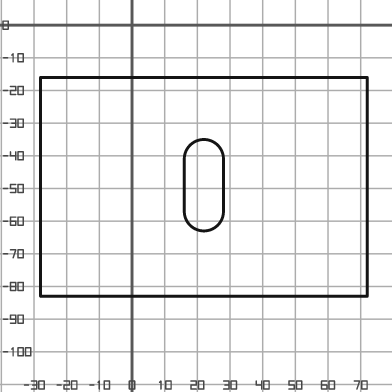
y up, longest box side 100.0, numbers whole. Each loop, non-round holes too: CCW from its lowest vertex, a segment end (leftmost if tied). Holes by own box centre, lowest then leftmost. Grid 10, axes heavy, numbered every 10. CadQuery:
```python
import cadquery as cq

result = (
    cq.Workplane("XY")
    .moveTo(-28.0, -83.0)
    .lineTo(72.0, -83.0)
    .lineTo(72.0, -16.0)
    .lineTo(-28.0, -16.0)
    .close()
    .moveTo(16.0, -57.0)
    .threePointArc((22.0, -63.0), (28.0, -57.0))
    .lineTo(28.0, -41.0)
    .threePointArc((22.0, -35.0), (16.0, -41.0))
    .close()
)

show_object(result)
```